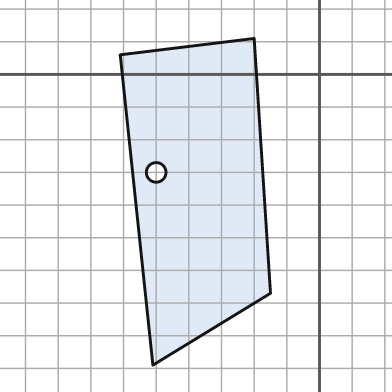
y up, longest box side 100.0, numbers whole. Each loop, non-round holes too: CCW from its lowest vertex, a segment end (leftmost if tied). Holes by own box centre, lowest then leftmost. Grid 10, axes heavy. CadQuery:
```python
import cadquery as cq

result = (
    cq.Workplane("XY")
    .moveTo(-51.0, -89.0)
    .lineTo(-15.0, -67.0)
    .lineTo(-20.0, 11.0)
    .lineTo(-61.0, 6.0)
    .close()
    .moveTo(-50.0, -30.0)
    .circle(3.0)
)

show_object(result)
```